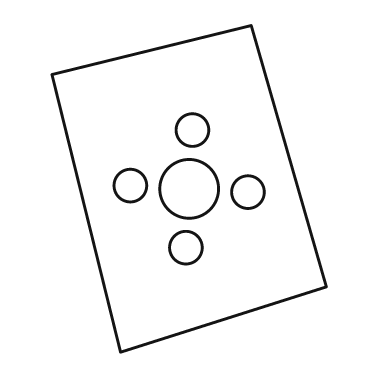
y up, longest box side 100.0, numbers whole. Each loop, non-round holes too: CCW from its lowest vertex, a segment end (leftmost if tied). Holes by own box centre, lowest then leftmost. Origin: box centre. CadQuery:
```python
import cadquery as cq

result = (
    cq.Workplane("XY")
    .moveTo(-21.0, -50.0)
    .lineTo(42.0, -30.0)
    .lineTo(19.0, 50.0)
    .lineTo(-42.0, 35.0)
    .close()
    .moveTo(-1.0, -18.0)
    .circle(5.0)
    .moveTo(18.0, -1.0)
    .circle(5.0)
    .moveTo(0.0, 0.0)
    .circle(9.0)
    .moveTo(-18.0, 1.0)
    .circle(5.0)
    .moveTo(1.0, 18.0)
    .circle(5.0)
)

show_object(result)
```